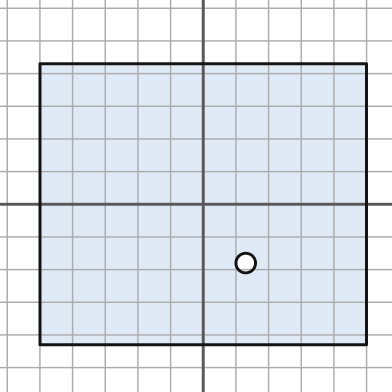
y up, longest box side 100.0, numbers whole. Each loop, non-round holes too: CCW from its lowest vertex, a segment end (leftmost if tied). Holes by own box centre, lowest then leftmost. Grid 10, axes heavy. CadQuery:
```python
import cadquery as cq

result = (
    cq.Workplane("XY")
    .moveTo(-50.0, -43.0)
    .lineTo(50.0, -43.0)
    .lineTo(50.0, 43.0)
    .lineTo(-50.0, 43.0)
    .close()
    .moveTo(13.0, -18.0)
    .circle(3.0)
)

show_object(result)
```